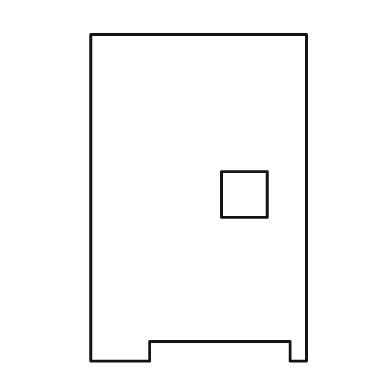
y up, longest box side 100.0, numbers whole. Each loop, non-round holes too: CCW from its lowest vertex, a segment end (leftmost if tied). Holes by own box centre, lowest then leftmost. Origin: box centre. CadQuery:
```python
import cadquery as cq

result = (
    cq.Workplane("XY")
    .moveTo(-33.0, -50.0)
    .lineTo(-15.0, -50.0)
    .lineTo(-15.0, -44.0)
    .lineTo(28.0, -44.0)
    .lineTo(28.0, -50.0)
    .lineTo(33.0, -50.0)
    .lineTo(33.0, 50.0)
    .lineTo(-33.0, 50.0)
    .close()
    .moveTo(7.0, -6.0)
    .lineTo(21.0, -6.0)
    .lineTo(21.0, 8.0)
    .lineTo(7.0, 8.0)
    .close()
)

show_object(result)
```